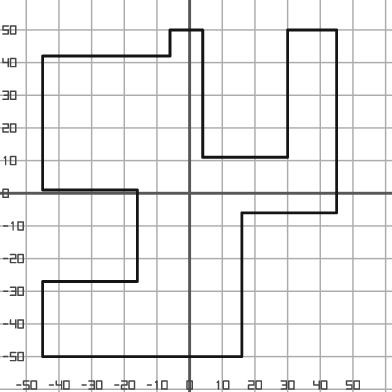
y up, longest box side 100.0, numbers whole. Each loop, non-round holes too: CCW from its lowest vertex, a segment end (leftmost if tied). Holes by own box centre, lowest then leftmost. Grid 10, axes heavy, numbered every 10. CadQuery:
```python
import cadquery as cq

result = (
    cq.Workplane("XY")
    .moveTo(-45.0, -50.0)
    .lineTo(16.0, -50.0)
    .lineTo(16.0, -6.0)
    .lineTo(45.0, -6.0)
    .lineTo(45.0, 50.0)
    .lineTo(30.0, 50.0)
    .lineTo(30.0, 11.0)
    .lineTo(4.0, 11.0)
    .lineTo(4.0, 50.0)
    .lineTo(-6.0, 50.0)
    .lineTo(-6.0, 42.0)
    .lineTo(-45.0, 42.0)
    .lineTo(-45.0, 1.0)
    .lineTo(-16.0, 1.0)
    .lineTo(-16.0, -27.0)
    .lineTo(-45.0, -27.0)
    .close()
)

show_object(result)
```